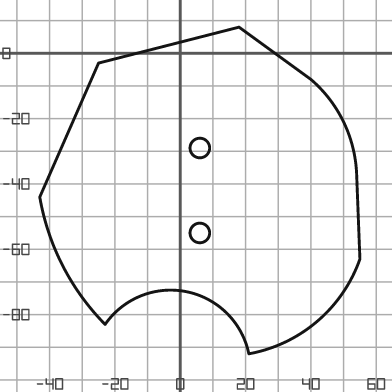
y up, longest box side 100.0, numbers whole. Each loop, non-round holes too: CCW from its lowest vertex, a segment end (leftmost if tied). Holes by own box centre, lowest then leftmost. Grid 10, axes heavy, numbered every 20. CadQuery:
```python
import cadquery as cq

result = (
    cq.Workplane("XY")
    .moveTo(21.0, -92.0)
    .threePointArc((42.0, -82.0), (55.0, -63.0))
    .lineTo(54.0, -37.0)
    .threePointArc((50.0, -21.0), (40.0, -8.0))
    .lineTo(18.0, 8.0)
    .lineTo(-25.0, -3.0)
    .lineTo(-43.0, -44.0)
    .threePointArc((-36.0, -65.0), (-23.0, -83.0))
    .threePointArc((2.0, -73.0), (21.0, -92.0))
    .close()
    .moveTo(6.0, -55.0)
    .circle(3.0)
    .moveTo(6.0, -29.0)
    .circle(3.0)
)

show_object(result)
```